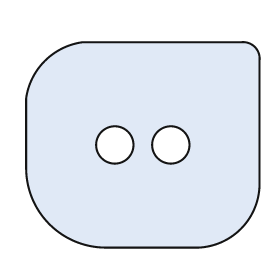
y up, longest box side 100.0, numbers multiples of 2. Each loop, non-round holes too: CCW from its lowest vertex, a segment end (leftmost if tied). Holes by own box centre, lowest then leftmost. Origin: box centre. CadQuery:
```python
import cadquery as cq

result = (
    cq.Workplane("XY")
    .moveTo(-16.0, -44.0)
    .lineTo(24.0, -44.0)
    .threePointArc((42.0, -36.0), (50.0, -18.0))
    .lineTo(50.0, 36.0)
    .threePointArc((48.0, 42.0), (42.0, 44.0))
    .lineTo(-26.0, 44.0)
    .threePointArc((-42.0, 36.0), (-50.0, 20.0))
    .lineTo(-50.0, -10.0)
    .threePointArc((-40.0, -34.0), (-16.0, -44.0))
    .close()
    .moveTo(-12.0, 0.0)
    .circle(8.0)
    .moveTo(12.0, 0.0)
    .circle(8.0)
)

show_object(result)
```